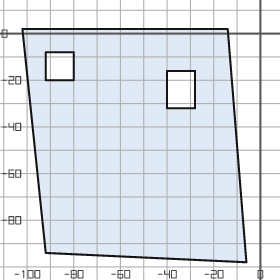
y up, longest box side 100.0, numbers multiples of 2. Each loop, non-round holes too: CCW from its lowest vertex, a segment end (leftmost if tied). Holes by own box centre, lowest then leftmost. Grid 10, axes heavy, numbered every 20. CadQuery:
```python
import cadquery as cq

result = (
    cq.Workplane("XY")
    .moveTo(-6.0, -98.0)
    .lineTo(-14.0, 2.0)
    .lineTo(-102.0, 2.0)
    .lineTo(-92.0, -94.0)
    .close()
    .moveTo(-40.0, -32.0)
    .lineTo(-28.0, -32.0)
    .lineTo(-28.0, -16.0)
    .lineTo(-40.0, -16.0)
    .close()
    .moveTo(-92.0, -20.0)
    .lineTo(-80.0, -20.0)
    .lineTo(-80.0, -8.0)
    .lineTo(-92.0, -8.0)
    .close()
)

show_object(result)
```